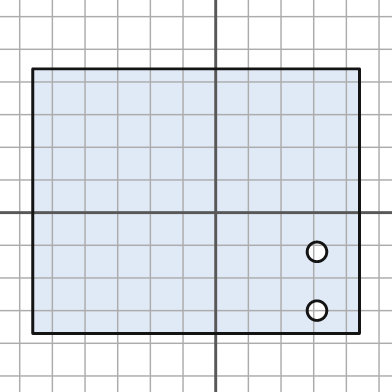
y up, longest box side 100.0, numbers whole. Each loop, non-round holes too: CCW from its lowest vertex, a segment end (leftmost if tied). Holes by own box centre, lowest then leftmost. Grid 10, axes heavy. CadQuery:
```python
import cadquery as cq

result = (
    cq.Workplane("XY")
    .moveTo(-56.0, -37.0)
    .lineTo(44.0, -37.0)
    .lineTo(44.0, 44.0)
    .lineTo(-56.0, 44.0)
    .close()
    .moveTo(31.0, -30.0)
    .circle(3.0)
    .moveTo(31.0, -12.0)
    .circle(3.0)
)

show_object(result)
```